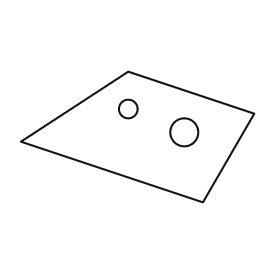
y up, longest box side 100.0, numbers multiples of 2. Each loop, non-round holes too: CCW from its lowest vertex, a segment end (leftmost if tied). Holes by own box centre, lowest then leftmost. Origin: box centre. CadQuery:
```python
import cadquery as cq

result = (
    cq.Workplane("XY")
    .moveTo(28.0, -28.0)
    .lineTo(50.0, 10.0)
    .lineTo(-4.0, 28.0)
    .lineTo(-50.0, -2.0)
    .close()
    .moveTo(20.0, 2.0)
    .circle(6.0)
    .moveTo(-4.0, 12.0)
    .circle(4.0)
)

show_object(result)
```